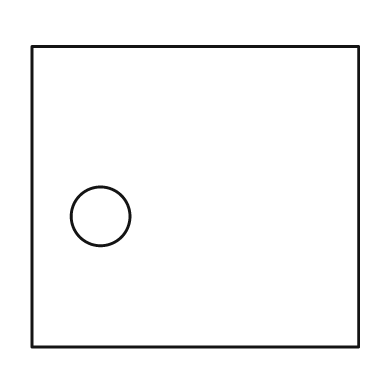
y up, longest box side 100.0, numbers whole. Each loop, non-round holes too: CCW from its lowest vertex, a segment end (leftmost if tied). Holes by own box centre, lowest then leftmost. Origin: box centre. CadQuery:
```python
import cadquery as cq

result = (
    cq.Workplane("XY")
    .moveTo(-50.0, -46.0)
    .lineTo(50.0, -46.0)
    .lineTo(50.0, 46.0)
    .lineTo(-50.0, 46.0)
    .close()
    .moveTo(-29.0, -6.0)
    .circle(9.0)
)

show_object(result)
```